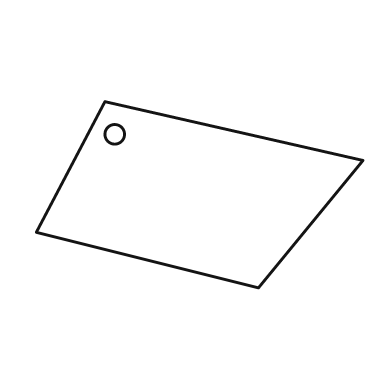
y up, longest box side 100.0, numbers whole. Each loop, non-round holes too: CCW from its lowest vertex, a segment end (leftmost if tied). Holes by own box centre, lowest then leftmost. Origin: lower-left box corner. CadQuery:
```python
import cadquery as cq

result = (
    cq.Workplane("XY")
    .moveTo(68.0, 0.0)
    .lineTo(100.0, 39.0)
    .lineTo(21.0, 57.0)
    .lineTo(0.0, 17.0)
    .close()
    .moveTo(24.0, 47.0)
    .circle(3.0)
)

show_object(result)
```